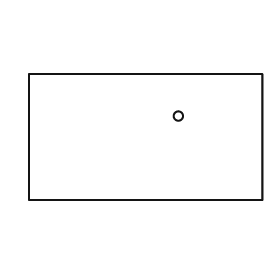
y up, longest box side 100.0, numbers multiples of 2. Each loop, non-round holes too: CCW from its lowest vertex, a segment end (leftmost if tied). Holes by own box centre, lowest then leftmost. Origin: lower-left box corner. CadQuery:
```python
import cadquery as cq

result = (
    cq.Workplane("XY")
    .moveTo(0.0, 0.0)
    .lineTo(100.0, 0.0)
    .lineTo(100.0, 54.0)
    .lineTo(0.0, 54.0)
    .close()
    .moveTo(64.0, 36.0)
    .circle(2.0)
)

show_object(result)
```